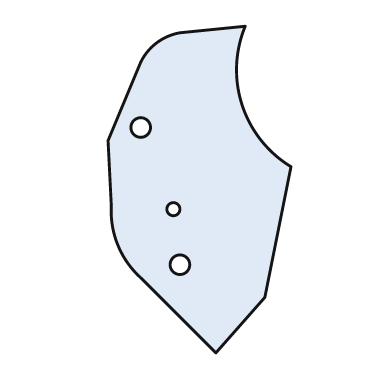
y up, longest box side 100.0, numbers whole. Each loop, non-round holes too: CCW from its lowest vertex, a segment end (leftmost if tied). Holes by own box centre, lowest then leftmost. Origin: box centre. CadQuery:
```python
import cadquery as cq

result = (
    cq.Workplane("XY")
    .moveTo(5.0, -50.0)
    .lineTo(20.0, -33.0)
    .lineTo(28.0, 7.0)
    .threePointArc((13.0, 26.0), (14.0, 50.0))
    .lineTo(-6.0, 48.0)
    .threePointArc((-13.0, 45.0), (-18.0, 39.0))
    .lineTo(-28.0, 15.0)
    .lineTo(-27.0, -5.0)
    .threePointArc((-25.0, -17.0), (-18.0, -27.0))
    .close()
    .moveTo(-6.0, -23.0)
    .circle(3.0)
    .moveTo(-8.0, -6.0)
    .circle(2.0)
    .moveTo(-18.0, 19.0)
    .circle(3.0)
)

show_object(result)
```